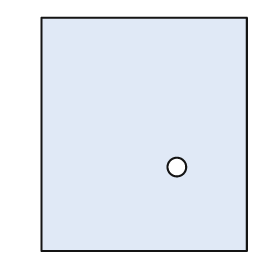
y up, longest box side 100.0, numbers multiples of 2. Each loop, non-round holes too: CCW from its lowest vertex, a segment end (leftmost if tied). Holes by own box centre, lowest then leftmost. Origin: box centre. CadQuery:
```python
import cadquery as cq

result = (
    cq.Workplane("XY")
    .moveTo(-44.0, -50.0)
    .lineTo(44.0, -50.0)
    .lineTo(44.0, 50.0)
    .lineTo(-44.0, 50.0)
    .close()
    .moveTo(14.0, -14.0)
    .circle(4.0)
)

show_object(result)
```